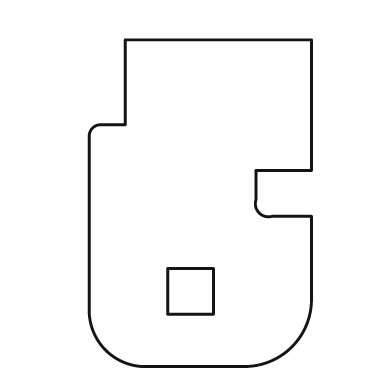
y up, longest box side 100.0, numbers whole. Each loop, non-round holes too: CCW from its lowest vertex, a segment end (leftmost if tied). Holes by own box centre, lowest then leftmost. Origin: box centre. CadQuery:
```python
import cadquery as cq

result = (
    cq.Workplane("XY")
    .moveTo(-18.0, -50.0)
    .lineTo(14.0, -50.0)
    .threePointArc((28.0, -44.0), (34.0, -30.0))
    .lineTo(34.0, -4.0)
    .lineTo(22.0, -4.0)
    .threePointArc((18.0, -3.0), (17.0, 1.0))
    .lineTo(17.0, 10.0)
    .lineTo(34.0, 10.0)
    .lineTo(34.0, 50.0)
    .lineTo(-23.0, 50.0)
    .lineTo(-23.0, 24.0)
    .lineTo(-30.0, 24.0)
    .threePointArc((-33.0, 23.0), (-34.0, 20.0))
    .lineTo(-34.0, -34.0)
    .threePointArc((-29.0, -45.0), (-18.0, -50.0))
    .close()
    .moveTo(-10.0, -34.0)
    .lineTo(4.0, -34.0)
    .lineTo(4.0, -20.0)
    .lineTo(-10.0, -20.0)
    .close()
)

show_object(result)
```